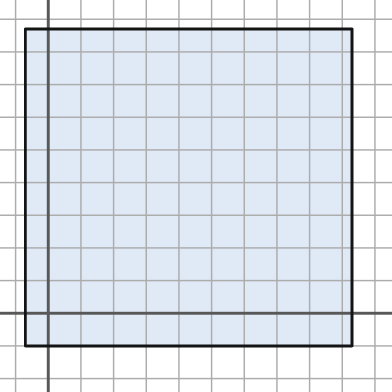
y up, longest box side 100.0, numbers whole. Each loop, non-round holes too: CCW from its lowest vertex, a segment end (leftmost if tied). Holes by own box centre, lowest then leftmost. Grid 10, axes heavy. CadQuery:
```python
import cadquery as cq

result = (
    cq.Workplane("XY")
    .moveTo(-7.0, -10.0)
    .lineTo(93.0, -10.0)
    .lineTo(93.0, 87.0)
    .lineTo(-7.0, 87.0)
    .close()
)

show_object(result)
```